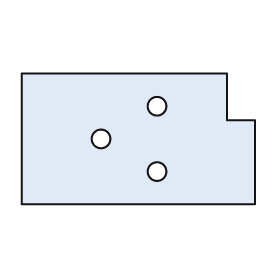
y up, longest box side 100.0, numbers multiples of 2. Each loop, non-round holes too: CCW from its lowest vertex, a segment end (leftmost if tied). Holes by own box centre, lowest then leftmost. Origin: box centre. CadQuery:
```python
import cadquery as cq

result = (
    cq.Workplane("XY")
    .moveTo(-50.0, -28.0)
    .lineTo(50.0, -28.0)
    .lineTo(50.0, 8.0)
    .lineTo(38.0, 8.0)
    .lineTo(38.0, 28.0)
    .lineTo(-50.0, 28.0)
    .close()
    .moveTo(8.0, -14.0)
    .circle(4.0)
    .moveTo(-16.0, 0.0)
    .circle(4.0)
    .moveTo(8.0, 14.0)
    .circle(4.0)
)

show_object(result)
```